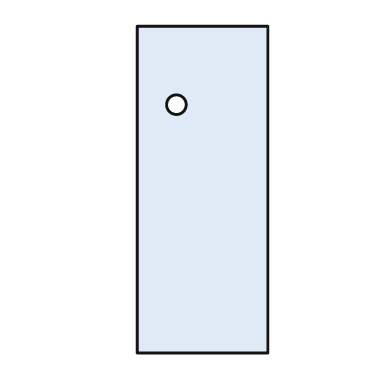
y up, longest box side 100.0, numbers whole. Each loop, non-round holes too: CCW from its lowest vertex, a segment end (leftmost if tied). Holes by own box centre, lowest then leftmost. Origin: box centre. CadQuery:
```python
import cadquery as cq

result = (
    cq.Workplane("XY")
    .moveTo(-20.0, -50.0)
    .lineTo(20.0, -50.0)
    .lineTo(20.0, 50.0)
    .lineTo(-20.0, 50.0)
    .close()
    .moveTo(-8.0, 26.0)
    .circle(3.0)
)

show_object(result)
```